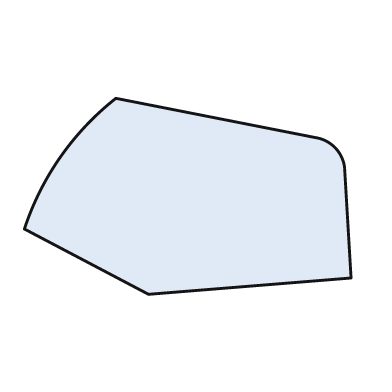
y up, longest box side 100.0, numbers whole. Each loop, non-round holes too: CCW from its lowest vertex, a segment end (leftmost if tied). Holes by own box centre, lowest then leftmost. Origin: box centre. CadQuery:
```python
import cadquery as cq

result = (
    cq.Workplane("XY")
    .moveTo(-12.0, -30.0)
    .lineTo(50.0, -25.0)
    .lineTo(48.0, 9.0)
    .threePointArc((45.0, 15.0), (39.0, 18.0))
    .lineTo(-22.0, 30.0)
    .threePointArc((-39.0, 12.0), (-50.0, -10.0))
    .close()
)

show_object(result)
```